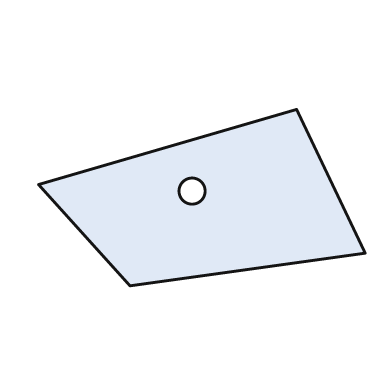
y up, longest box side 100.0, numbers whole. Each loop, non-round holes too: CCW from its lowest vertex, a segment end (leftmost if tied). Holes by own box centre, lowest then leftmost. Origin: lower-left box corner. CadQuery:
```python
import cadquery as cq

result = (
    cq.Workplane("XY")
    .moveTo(28.0, 0.0)
    .lineTo(100.0, 10.0)
    .lineTo(79.0, 54.0)
    .lineTo(0.0, 31.0)
    .close()
    .moveTo(47.0, 29.0)
    .circle(4.0)
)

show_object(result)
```